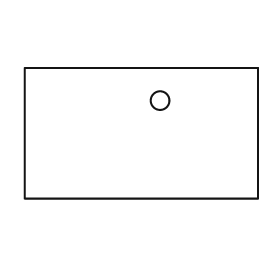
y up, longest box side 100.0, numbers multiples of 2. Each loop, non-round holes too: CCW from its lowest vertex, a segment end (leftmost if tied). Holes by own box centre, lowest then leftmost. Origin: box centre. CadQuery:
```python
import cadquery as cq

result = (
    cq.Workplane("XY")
    .moveTo(-50.0, -28.0)
    .lineTo(50.0, -28.0)
    .lineTo(50.0, 28.0)
    .lineTo(-50.0, 28.0)
    .close()
    .moveTo(8.0, 14.0)
    .circle(4.0)
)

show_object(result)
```